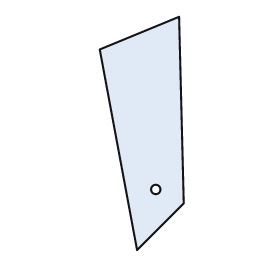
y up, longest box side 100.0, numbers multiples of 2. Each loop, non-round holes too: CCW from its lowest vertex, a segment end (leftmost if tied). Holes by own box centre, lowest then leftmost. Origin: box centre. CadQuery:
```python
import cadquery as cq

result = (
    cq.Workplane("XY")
    .moveTo(-2.0, -50.0)
    .lineTo(18.0, -30.0)
    .lineTo(16.0, 50.0)
    .lineTo(-18.0, 36.0)
    .close()
    .moveTo(6.0, -24.0)
    .circle(2.0)
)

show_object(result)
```